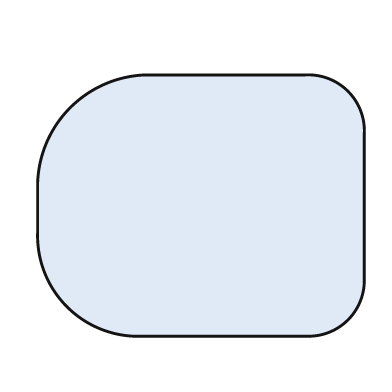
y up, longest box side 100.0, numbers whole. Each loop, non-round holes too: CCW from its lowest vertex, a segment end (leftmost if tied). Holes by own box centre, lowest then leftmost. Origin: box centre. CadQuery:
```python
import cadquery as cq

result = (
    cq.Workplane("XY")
    .moveTo(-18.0, -40.0)
    .lineTo(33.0, -40.0)
    .threePointArc((45.0, -35.0), (50.0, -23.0))
    .lineTo(50.0, 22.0)
    .threePointArc((45.0, 35.0), (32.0, 40.0))
    .lineTo(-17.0, 40.0)
    .threePointArc((-40.0, 30.0), (-50.0, 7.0))
    .lineTo(-50.0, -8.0)
    .threePointArc((-41.0, -31.0), (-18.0, -40.0))
    .close()
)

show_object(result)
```